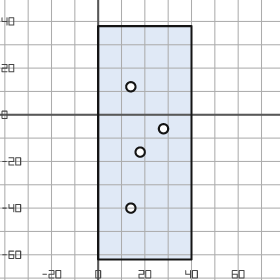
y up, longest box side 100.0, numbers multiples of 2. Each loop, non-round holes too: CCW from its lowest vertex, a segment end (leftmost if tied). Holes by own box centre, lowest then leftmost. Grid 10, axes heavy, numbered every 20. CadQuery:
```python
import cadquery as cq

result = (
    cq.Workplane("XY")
    .moveTo(0.0, -62.0)
    .lineTo(40.0, -62.0)
    .lineTo(40.0, 38.0)
    .lineTo(0.0, 38.0)
    .close()
    .moveTo(14.0, -40.0)
    .circle(2.0)
    .moveTo(18.0, -16.0)
    .circle(2.0)
    .moveTo(28.0, -6.0)
    .circle(2.0)
    .moveTo(14.0, 12.0)
    .circle(2.0)
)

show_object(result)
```